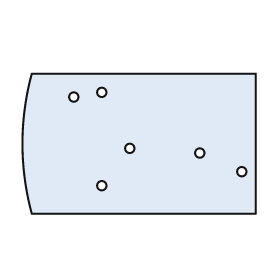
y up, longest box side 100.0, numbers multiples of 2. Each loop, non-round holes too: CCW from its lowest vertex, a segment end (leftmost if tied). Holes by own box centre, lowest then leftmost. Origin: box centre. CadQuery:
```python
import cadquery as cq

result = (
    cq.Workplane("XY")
    .moveTo(-46.0, -30.0)
    .lineTo(50.0, -30.0)
    .lineTo(50.0, 30.0)
    .lineTo(-46.0, 30.0)
    .threePointArc((-50.0, 0.0), (-46.0, -30.0))
    .close()
    .moveTo(-16.0, -18.0)
    .circle(2.0)
    .moveTo(44.0, -12.0)
    .circle(2.0)
    .moveTo(26.0, -4.0)
    .circle(2.0)
    .moveTo(-4.0, -2.0)
    .circle(2.0)
    .moveTo(-28.0, 20.0)
    .circle(2.0)
    .moveTo(-16.0, 22.0)
    .circle(2.0)
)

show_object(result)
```